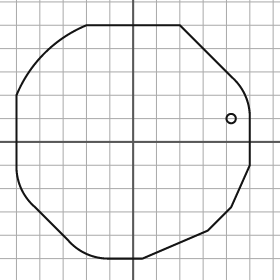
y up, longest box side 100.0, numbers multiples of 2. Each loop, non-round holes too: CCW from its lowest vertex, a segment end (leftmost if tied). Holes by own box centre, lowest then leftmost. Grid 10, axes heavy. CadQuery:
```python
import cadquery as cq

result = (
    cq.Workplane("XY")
    .moveTo(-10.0, -50.0)
    .lineTo(4.0, -50.0)
    .lineTo(32.0, -38.0)
    .lineTo(42.0, -28.0)
    .lineTo(50.0, -10.0)
    .lineTo(50.0, 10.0)
    .threePointArc((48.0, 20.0), (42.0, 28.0))
    .lineTo(20.0, 50.0)
    .lineTo(-20.0, 50.0)
    .threePointArc((-38.0, 38.0), (-50.0, 20.0))
    .lineTo(-50.0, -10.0)
    .threePointArc((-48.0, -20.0), (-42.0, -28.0))
    .lineTo(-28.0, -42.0)
    .threePointArc((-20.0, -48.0), (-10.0, -50.0))
    .close()
    .moveTo(42.0, 10.0)
    .circle(2.0)
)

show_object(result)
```